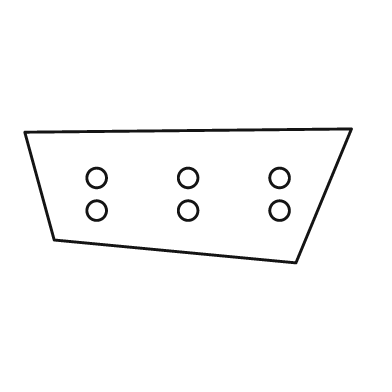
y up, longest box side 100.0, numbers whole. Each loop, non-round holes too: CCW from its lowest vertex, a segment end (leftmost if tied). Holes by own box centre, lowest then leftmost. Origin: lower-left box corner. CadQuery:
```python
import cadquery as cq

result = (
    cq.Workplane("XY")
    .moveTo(83.0, 0.0)
    .lineTo(100.0, 41.0)
    .lineTo(0.0, 40.0)
    .lineTo(9.0, 7.0)
    .close()
    .moveTo(22.0, 16.0)
    .circle(3.0)
    .moveTo(50.0, 16.0)
    .circle(3.0)
    .moveTo(78.0, 16.0)
    .circle(3.0)
    .moveTo(22.0, 26.0)
    .circle(3.0)
    .moveTo(50.0, 26.0)
    .circle(3.0)
    .moveTo(78.0, 26.0)
    .circle(3.0)
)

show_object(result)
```